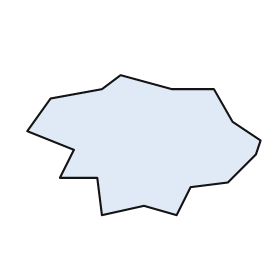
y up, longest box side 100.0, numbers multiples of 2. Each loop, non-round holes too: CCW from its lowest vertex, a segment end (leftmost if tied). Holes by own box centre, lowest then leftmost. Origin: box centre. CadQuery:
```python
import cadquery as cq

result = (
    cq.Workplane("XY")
    .moveTo(-18.0, -30.0)
    .lineTo(0.0, -26.0)
    .lineTo(14.0, -30.0)
    .lineTo(20.0, -18.0)
    .lineTo(36.0, -16.0)
    .lineTo(48.0, -4.0)
    .lineTo(50.0, 2.0)
    .lineTo(38.0, 10.0)
    .lineTo(30.0, 24.0)
    .lineTo(12.0, 24.0)
    .lineTo(-10.0, 30.0)
    .lineTo(-18.0, 24.0)
    .lineTo(-40.0, 20.0)
    .lineTo(-50.0, 6.0)
    .lineTo(-30.0, -2.0)
    .lineTo(-36.0, -14.0)
    .lineTo(-20.0, -14.0)
    .close()
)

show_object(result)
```